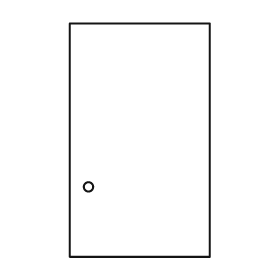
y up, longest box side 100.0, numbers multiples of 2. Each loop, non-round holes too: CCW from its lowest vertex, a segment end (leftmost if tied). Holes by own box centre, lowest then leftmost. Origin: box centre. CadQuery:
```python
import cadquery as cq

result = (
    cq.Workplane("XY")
    .moveTo(-30.0, -50.0)
    .lineTo(30.0, -50.0)
    .lineTo(30.0, 50.0)
    .lineTo(-30.0, 50.0)
    .close()
    .moveTo(-22.0, -20.0)
    .circle(2.0)
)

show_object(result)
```